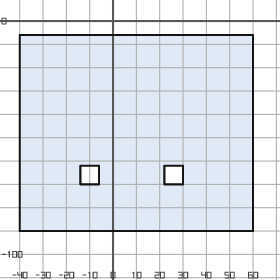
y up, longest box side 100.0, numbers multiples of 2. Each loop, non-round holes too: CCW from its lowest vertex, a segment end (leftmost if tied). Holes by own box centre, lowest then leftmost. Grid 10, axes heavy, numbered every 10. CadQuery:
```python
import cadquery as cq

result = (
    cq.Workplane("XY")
    .moveTo(-40.0, -90.0)
    .lineTo(60.0, -90.0)
    .lineTo(60.0, -6.0)
    .lineTo(-40.0, -6.0)
    .close()
    .moveTo(-14.0, -70.0)
    .lineTo(-6.0, -70.0)
    .lineTo(-6.0, -62.0)
    .lineTo(-14.0, -62.0)
    .close()
    .moveTo(22.0, -70.0)
    .lineTo(30.0, -70.0)
    .lineTo(30.0, -62.0)
    .lineTo(22.0, -62.0)
    .close()
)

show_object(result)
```